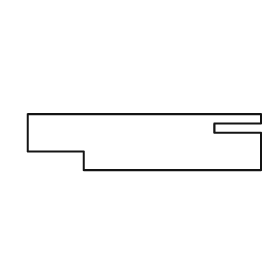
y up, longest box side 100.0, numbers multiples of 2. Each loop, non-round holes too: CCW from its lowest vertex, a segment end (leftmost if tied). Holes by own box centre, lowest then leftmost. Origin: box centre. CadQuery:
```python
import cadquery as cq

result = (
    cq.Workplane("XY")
    .moveTo(-26.0, -12.0)
    .lineTo(50.0, -12.0)
    .lineTo(50.0, 4.0)
    .lineTo(30.0, 4.0)
    .lineTo(30.0, 8.0)
    .lineTo(50.0, 8.0)
    .lineTo(50.0, 12.0)
    .lineTo(-50.0, 12.0)
    .lineTo(-50.0, -4.0)
    .lineTo(-26.0, -4.0)
    .close()
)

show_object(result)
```